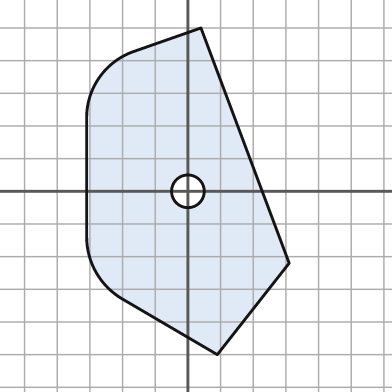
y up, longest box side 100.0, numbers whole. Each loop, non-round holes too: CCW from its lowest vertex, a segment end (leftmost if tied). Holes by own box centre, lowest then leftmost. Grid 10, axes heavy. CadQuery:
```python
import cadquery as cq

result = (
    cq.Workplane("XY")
    .moveTo(9.0, -50.0)
    .lineTo(31.0, -22.0)
    .lineTo(4.0, 50.0)
    .lineTo(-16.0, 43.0)
    .threePointArc((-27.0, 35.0), (-31.0, 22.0))
    .lineTo(-31.0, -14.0)
    .threePointArc((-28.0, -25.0), (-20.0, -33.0))
    .close()
    .moveTo(0.0, 0.0)
    .circle(5.0)
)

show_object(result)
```